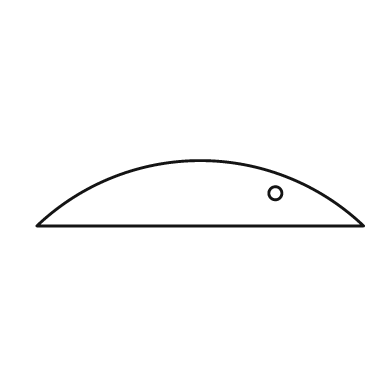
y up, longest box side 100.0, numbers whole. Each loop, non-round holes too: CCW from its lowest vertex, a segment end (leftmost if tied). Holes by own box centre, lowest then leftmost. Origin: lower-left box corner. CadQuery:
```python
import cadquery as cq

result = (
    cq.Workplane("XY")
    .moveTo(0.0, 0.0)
    .lineTo(100.0, 0.0)
    .threePointArc((50.0, 20.0), (0.0, 0.0))
    .close()
    .moveTo(73.0, 10.0)
    .circle(2.0)
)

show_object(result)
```